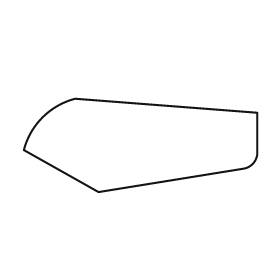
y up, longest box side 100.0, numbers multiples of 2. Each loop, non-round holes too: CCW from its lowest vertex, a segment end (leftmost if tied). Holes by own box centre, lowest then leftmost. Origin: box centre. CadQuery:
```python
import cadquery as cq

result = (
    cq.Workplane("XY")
    .moveTo(-18.0, -20.0)
    .lineTo(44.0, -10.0)
    .threePointArc((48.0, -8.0), (50.0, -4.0))
    .lineTo(50.0, 14.0)
    .lineTo(-28.0, 20.0)
    .threePointArc((-42.0, 12.0), (-50.0, -2.0))
    .close()
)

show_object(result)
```